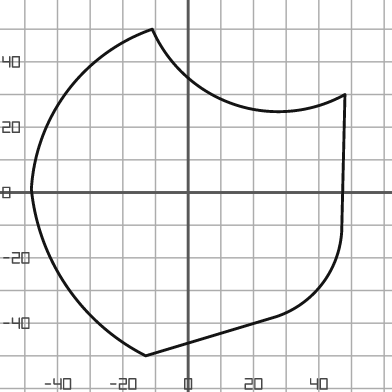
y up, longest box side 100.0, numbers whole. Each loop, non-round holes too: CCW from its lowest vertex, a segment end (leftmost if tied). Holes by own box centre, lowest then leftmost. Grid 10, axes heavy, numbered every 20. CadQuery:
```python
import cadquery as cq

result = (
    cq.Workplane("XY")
    .moveTo(-13.0, -50.0)
    .lineTo(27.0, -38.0)
    .threePointArc((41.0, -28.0), (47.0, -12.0))
    .lineTo(48.0, 30.0)
    .threePointArc((14.0, 27.0), (-11.0, 50.0))
    .threePointArc((-37.0, 31.0), (-48.0, 1.0))
    .threePointArc((-37.0, -29.0), (-13.0, -50.0))
    .close()
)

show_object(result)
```